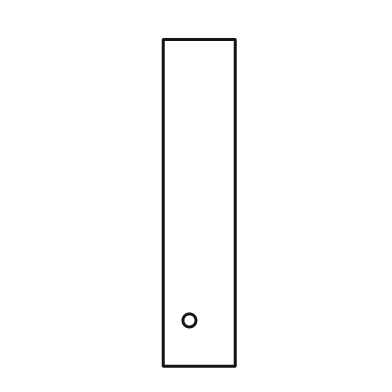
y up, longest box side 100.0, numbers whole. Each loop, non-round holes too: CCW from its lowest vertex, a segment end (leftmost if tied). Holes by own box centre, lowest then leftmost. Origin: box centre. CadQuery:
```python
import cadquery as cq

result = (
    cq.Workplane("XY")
    .moveTo(-11.0, -50.0)
    .lineTo(11.0, -50.0)
    .lineTo(11.0, 50.0)
    .lineTo(-11.0, 50.0)
    .close()
    .moveTo(-3.0, -36.0)
    .circle(2.0)
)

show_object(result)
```